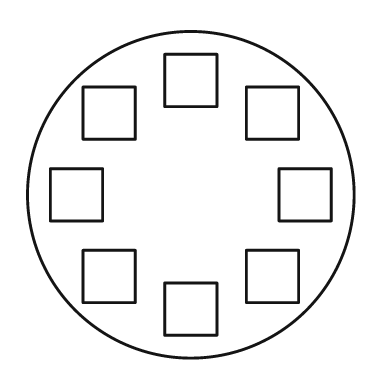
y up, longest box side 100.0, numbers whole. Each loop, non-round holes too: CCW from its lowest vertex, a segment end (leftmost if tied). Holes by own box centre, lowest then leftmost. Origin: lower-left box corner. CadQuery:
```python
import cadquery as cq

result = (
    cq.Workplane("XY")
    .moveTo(50.0, 50.0)
    .circle(50.0)
    .moveTo(42.0, 7.0)
    .lineTo(58.0, 7.0)
    .lineTo(58.0, 23.0)
    .lineTo(42.0, 23.0)
    .close()
    .moveTo(17.0, 17.0)
    .lineTo(33.0, 17.0)
    .lineTo(33.0, 33.0)
    .lineTo(17.0, 33.0)
    .close()
    .moveTo(67.0, 17.0)
    .lineTo(83.0, 17.0)
    .lineTo(83.0, 33.0)
    .lineTo(67.0, 33.0)
    .close()
    .moveTo(7.0, 42.0)
    .lineTo(23.0, 42.0)
    .lineTo(23.0, 58.0)
    .lineTo(7.0, 58.0)
    .close()
    .moveTo(77.0, 42.0)
    .lineTo(93.0, 42.0)
    .lineTo(93.0, 58.0)
    .lineTo(77.0, 58.0)
    .close()
    .moveTo(17.0, 67.0)
    .lineTo(33.0, 67.0)
    .lineTo(33.0, 83.0)
    .lineTo(17.0, 83.0)
    .close()
    .moveTo(67.0, 67.0)
    .lineTo(83.0, 67.0)
    .lineTo(83.0, 83.0)
    .lineTo(67.0, 83.0)
    .close()
    .moveTo(42.0, 77.0)
    .lineTo(58.0, 77.0)
    .lineTo(58.0, 93.0)
    .lineTo(42.0, 93.0)
    .close()
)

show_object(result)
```